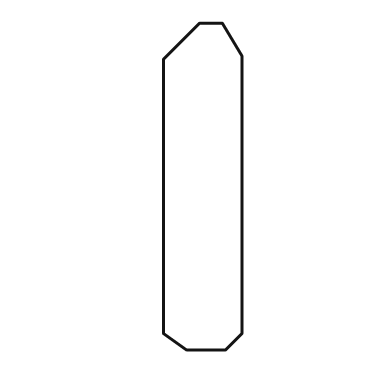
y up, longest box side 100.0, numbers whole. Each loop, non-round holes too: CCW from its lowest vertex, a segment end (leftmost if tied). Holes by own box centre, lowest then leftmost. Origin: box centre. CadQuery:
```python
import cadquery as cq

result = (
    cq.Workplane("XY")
    .moveTo(-5.0, -50.0)
    .lineTo(7.0, -50.0)
    .lineTo(12.0, -45.0)
    .lineTo(12.0, 40.0)
    .lineTo(6.0, 50.0)
    .lineTo(-1.0, 50.0)
    .lineTo(-12.0, 39.0)
    .lineTo(-12.0, -45.0)
    .close()
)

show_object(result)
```